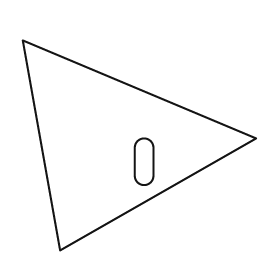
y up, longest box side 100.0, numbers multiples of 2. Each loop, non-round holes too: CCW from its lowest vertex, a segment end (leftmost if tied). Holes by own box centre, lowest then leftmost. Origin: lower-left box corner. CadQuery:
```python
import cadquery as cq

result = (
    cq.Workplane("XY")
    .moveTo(16.0, 0.0)
    .lineTo(100.0, 48.0)
    .lineTo(0.0, 90.0)
    .close()
    .moveTo(48.0, 32.0)
    .threePointArc((52.0, 28.0), (56.0, 32.0))
    .lineTo(56.0, 44.0)
    .threePointArc((52.0, 48.0), (48.0, 44.0))
    .close()
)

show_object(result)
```